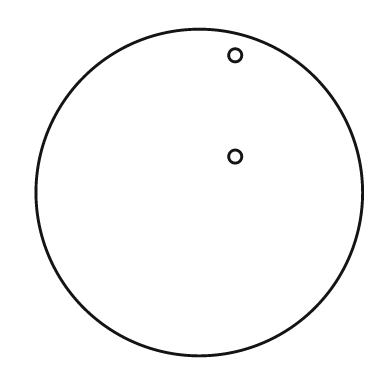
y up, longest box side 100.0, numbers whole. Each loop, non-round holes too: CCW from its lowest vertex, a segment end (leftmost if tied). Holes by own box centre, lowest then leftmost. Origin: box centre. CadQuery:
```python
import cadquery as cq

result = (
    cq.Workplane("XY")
    .moveTo(0.0, 0.0)
    .circle(50.0)
    .moveTo(11.0, 11.0)
    .circle(2.0)
    .moveTo(11.0, 42.0)
    .circle(2.0)
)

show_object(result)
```